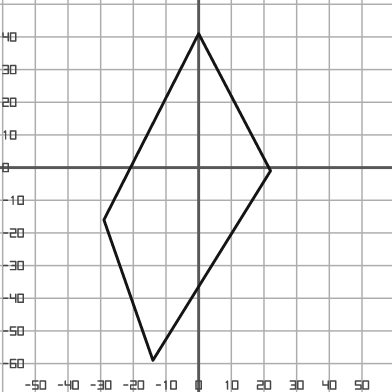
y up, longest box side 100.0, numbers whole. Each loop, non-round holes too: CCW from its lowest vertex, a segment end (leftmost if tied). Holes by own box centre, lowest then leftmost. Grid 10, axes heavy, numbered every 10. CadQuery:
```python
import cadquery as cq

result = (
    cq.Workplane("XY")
    .moveTo(-14.0, -59.0)
    .lineTo(22.0, -1.0)
    .lineTo(0.0, 41.0)
    .lineTo(-29.0, -16.0)
    .close()
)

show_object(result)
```